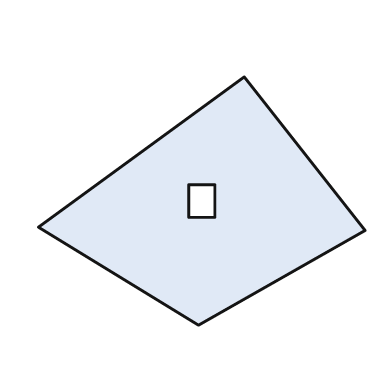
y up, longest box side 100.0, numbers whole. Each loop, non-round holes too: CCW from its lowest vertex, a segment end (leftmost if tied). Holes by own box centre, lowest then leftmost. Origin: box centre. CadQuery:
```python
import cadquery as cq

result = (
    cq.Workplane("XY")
    .moveTo(-1.0, -38.0)
    .lineTo(50.0, -9.0)
    .lineTo(13.0, 38.0)
    .lineTo(-50.0, -8.0)
    .close()
    .moveTo(-4.0, -5.0)
    .lineTo(4.0, -5.0)
    .lineTo(4.0, 5.0)
    .lineTo(-4.0, 5.0)
    .close()
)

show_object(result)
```